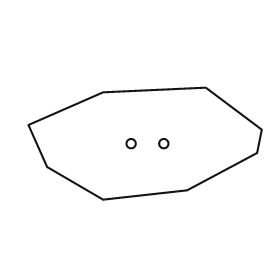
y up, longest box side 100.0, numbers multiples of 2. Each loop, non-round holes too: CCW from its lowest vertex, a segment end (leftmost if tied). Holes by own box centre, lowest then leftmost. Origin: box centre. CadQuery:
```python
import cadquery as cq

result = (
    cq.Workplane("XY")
    .moveTo(-18.0, -24.0)
    .lineTo(18.0, -20.0)
    .lineTo(48.0, -4.0)
    .lineTo(50.0, 6.0)
    .lineTo(26.0, 24.0)
    .lineTo(-18.0, 22.0)
    .lineTo(-50.0, 8.0)
    .lineTo(-42.0, -10.0)
    .close()
    .moveTo(-6.0, 0.0)
    .circle(2.0)
    .moveTo(8.0, 0.0)
    .circle(2.0)
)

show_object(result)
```